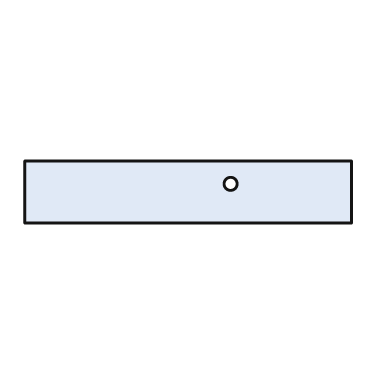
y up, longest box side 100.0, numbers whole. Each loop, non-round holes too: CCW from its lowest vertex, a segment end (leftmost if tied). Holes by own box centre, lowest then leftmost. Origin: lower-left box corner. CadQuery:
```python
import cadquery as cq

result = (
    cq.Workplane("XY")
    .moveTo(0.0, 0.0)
    .lineTo(100.0, 0.0)
    .lineTo(100.0, 19.0)
    .lineTo(0.0, 19.0)
    .close()
    .moveTo(63.0, 12.0)
    .circle(2.0)
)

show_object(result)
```